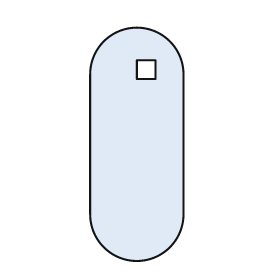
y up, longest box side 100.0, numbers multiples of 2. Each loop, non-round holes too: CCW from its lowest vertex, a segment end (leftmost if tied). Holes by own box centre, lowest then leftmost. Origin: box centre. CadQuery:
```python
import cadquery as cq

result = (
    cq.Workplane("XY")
    .moveTo(-20.0, -30.0)
    .threePointArc((0.0, -50.0), (20.0, -30.0))
    .lineTo(20.0, 30.0)
    .threePointArc((0.0, 50.0), (-20.0, 30.0))
    .close()
    .moveTo(0.0, 28.0)
    .lineTo(8.0, 28.0)
    .lineTo(8.0, 36.0)
    .lineTo(0.0, 36.0)
    .close()
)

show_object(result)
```